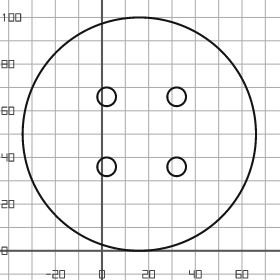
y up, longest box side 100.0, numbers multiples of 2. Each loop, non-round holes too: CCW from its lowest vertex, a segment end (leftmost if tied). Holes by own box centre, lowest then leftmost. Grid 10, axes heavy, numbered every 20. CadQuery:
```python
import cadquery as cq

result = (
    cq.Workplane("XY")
    .moveTo(16.0, 50.0)
    .circle(50.0)
    .moveTo(2.0, 36.0)
    .circle(4.0)
    .moveTo(32.0, 36.0)
    .circle(4.0)
    .moveTo(2.0, 66.0)
    .circle(4.0)
    .moveTo(32.0, 66.0)
    .circle(4.0)
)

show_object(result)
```